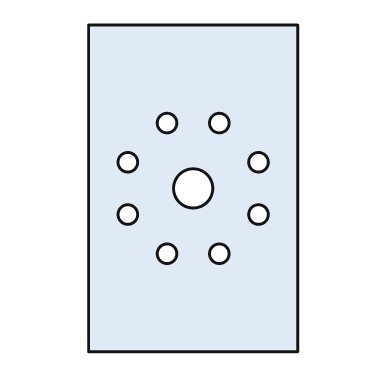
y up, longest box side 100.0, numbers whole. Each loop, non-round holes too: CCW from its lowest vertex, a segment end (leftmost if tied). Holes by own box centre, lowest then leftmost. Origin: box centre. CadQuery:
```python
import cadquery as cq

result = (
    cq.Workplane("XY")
    .moveTo(-32.0, -50.0)
    .lineTo(32.0, -50.0)
    .lineTo(32.0, 50.0)
    .lineTo(-32.0, 50.0)
    .close()
    .moveTo(-8.0, -20.0)
    .circle(3.0)
    .moveTo(8.0, -20.0)
    .circle(3.0)
    .moveTo(-20.0, -8.0)
    .circle(3.0)
    .moveTo(20.0, -8.0)
    .circle(3.0)
    .moveTo(0.0, 0.0)
    .circle(6.0)
    .moveTo(-20.0, 8.0)
    .circle(3.0)
    .moveTo(20.0, 8.0)
    .circle(3.0)
    .moveTo(-8.0, 20.0)
    .circle(3.0)
    .moveTo(8.0, 20.0)
    .circle(3.0)
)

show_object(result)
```